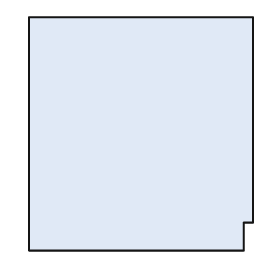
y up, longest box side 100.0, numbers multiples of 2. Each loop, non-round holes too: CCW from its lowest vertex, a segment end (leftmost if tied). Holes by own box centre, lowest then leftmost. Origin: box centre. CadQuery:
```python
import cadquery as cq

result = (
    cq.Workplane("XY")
    .moveTo(-48.0, -50.0)
    .lineTo(44.0, -50.0)
    .lineTo(44.0, -38.0)
    .lineTo(48.0, -38.0)
    .lineTo(48.0, 50.0)
    .lineTo(-48.0, 50.0)
    .close()
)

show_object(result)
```